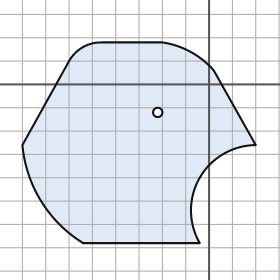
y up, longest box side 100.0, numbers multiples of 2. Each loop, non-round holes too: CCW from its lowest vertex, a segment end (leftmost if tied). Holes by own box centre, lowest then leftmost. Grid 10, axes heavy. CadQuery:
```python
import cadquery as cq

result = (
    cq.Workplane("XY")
    .moveTo(-54.0, -68.0)
    .lineTo(-4.0, -68.0)
    .threePointArc((-4.0, -40.0), (20.0, -26.0))
    .lineTo(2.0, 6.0)
    .threePointArc((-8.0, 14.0), (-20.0, 18.0))
    .lineTo(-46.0, 18.0)
    .threePointArc((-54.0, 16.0), (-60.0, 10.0))
    .lineTo(-80.0, -26.0)
    .threePointArc((-72.0, -50.0), (-54.0, -68.0))
    .close()
    .moveTo(-22.0, -12.0)
    .circle(2.0)
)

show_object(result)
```